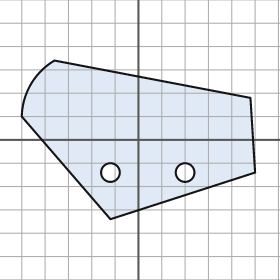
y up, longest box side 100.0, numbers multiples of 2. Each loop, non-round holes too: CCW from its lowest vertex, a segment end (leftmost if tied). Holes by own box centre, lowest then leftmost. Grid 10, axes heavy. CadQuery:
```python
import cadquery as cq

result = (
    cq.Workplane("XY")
    .moveTo(-12.0, -34.0)
    .lineTo(50.0, -14.0)
    .lineTo(48.0, 18.0)
    .lineTo(-36.0, 34.0)
    .threePointArc((-46.0, 24.0), (-50.0, 10.0))
    .close()
    .moveTo(-12.0, -14.0)
    .circle(4.0)
    .moveTo(20.0, -14.0)
    .circle(4.0)
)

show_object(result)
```